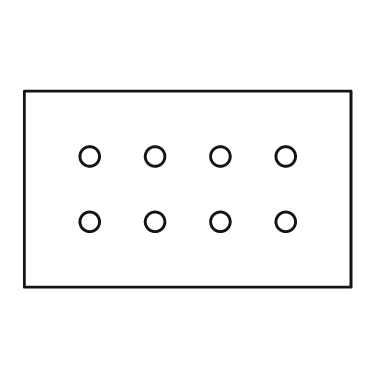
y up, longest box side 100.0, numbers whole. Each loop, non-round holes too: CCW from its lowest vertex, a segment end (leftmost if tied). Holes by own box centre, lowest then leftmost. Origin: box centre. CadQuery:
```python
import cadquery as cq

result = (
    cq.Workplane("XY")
    .moveTo(-50.0, -30.0)
    .lineTo(50.0, -30.0)
    .lineTo(50.0, 30.0)
    .lineTo(-50.0, 30.0)
    .close()
    .moveTo(-30.0, -10.0)
    .circle(3.0)
    .moveTo(-10.0, -10.0)
    .circle(3.0)
    .moveTo(10.0, -10.0)
    .circle(3.0)
    .moveTo(30.0, -10.0)
    .circle(3.0)
    .moveTo(-30.0, 10.0)
    .circle(3.0)
    .moveTo(-10.0, 10.0)
    .circle(3.0)
    .moveTo(10.0, 10.0)
    .circle(3.0)
    .moveTo(30.0, 10.0)
    .circle(3.0)
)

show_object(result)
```